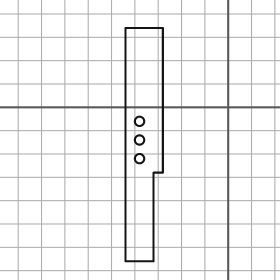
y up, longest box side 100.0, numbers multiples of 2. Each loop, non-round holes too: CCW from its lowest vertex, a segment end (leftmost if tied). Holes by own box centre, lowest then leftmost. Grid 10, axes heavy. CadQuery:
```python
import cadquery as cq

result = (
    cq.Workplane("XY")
    .moveTo(-44.0, -66.0)
    .lineTo(-32.0, -66.0)
    .lineTo(-32.0, -28.0)
    .lineTo(-28.0, -28.0)
    .lineTo(-28.0, 34.0)
    .lineTo(-44.0, 34.0)
    .close()
    .moveTo(-38.0, -22.0)
    .circle(2.0)
    .moveTo(-38.0, -14.0)
    .circle(2.0)
    .moveTo(-38.0, -6.0)
    .circle(2.0)
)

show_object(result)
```